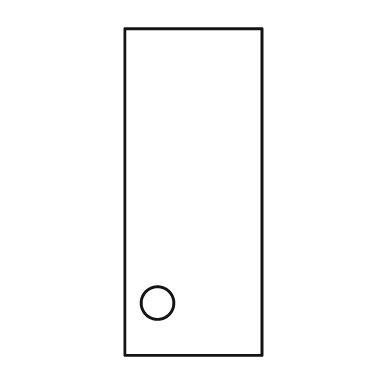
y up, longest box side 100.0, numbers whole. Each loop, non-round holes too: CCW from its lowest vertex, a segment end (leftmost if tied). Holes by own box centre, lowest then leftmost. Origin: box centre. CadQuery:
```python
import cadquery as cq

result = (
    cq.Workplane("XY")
    .moveTo(-21.0, -50.0)
    .lineTo(21.0, -50.0)
    .lineTo(21.0, 50.0)
    .lineTo(-21.0, 50.0)
    .close()
    .moveTo(-11.0, -34.0)
    .circle(5.0)
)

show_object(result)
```